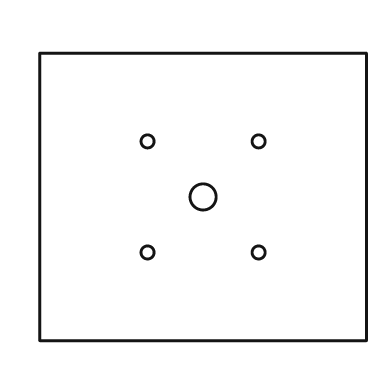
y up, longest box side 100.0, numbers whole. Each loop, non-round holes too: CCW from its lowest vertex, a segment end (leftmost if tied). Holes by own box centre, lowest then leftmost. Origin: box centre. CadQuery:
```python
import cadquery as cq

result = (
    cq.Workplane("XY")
    .moveTo(-50.0, -44.0)
    .lineTo(50.0, -44.0)
    .lineTo(50.0, 44.0)
    .lineTo(-50.0, 44.0)
    .close()
    .moveTo(-17.0, -17.0)
    .circle(2.0)
    .moveTo(17.0, -17.0)
    .circle(2.0)
    .moveTo(0.0, 0.0)
    .circle(4.0)
    .moveTo(-17.0, 17.0)
    .circle(2.0)
    .moveTo(17.0, 17.0)
    .circle(2.0)
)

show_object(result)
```